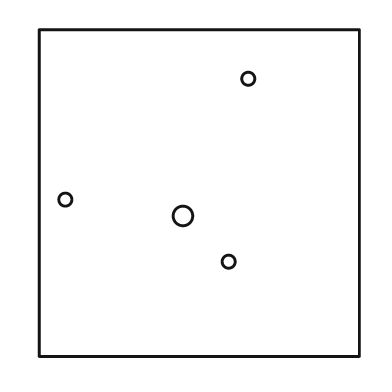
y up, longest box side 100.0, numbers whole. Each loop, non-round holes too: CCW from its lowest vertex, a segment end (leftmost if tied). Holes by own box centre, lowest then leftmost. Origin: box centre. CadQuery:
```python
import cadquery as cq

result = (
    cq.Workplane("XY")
    .moveTo(-49.0, -50.0)
    .lineTo(49.0, -50.0)
    .lineTo(49.0, 50.0)
    .lineTo(-49.0, 50.0)
    .close()
    .moveTo(9.0, -21.0)
    .circle(2.0)
    .moveTo(-5.0, -7.0)
    .circle(3.0)
    .moveTo(-41.0, -2.0)
    .circle(2.0)
    .moveTo(15.0, 35.0)
    .circle(2.0)
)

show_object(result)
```